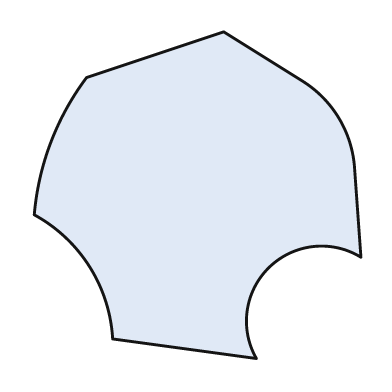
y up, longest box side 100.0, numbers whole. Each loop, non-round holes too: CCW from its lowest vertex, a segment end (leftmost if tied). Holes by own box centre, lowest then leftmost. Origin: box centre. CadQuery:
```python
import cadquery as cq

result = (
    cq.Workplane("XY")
    .moveTo(18.0, -50.0)
    .threePointArc((22.0, -22.0), (50.0, -19.0))
    .lineTo(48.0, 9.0)
    .threePointArc((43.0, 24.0), (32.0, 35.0))
    .lineTo(8.0, 50.0)
    .lineTo(-34.0, 36.0)
    .threePointArc((-45.0, 16.0), (-50.0, -6.0))
    .threePointArc((-33.0, -22.0), (-26.0, -44.0))
    .close()
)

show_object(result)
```